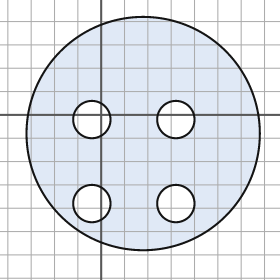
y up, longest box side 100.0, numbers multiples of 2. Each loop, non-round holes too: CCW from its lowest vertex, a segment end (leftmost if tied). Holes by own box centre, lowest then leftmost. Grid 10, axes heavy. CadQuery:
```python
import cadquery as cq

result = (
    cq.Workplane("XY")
    .moveTo(18.0, -8.0)
    .circle(50.0)
    .moveTo(-4.0, -38.0)
    .circle(8.0)
    .moveTo(32.0, -38.0)
    .circle(8.0)
    .moveTo(-4.0, -2.0)
    .circle(8.0)
    .moveTo(32.0, -2.0)
    .circle(8.0)
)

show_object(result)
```